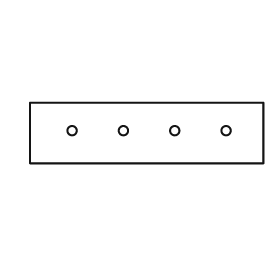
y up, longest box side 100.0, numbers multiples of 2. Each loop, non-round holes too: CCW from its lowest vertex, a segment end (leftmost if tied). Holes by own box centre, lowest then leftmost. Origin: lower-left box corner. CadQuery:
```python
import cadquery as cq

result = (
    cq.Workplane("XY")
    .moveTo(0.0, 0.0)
    .lineTo(100.0, 0.0)
    .lineTo(100.0, 26.0)
    .lineTo(0.0, 26.0)
    .close()
    .moveTo(18.0, 14.0)
    .circle(2.0)
    .moveTo(40.0, 14.0)
    .circle(2.0)
    .moveTo(62.0, 14.0)
    .circle(2.0)
    .moveTo(84.0, 14.0)
    .circle(2.0)
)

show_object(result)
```